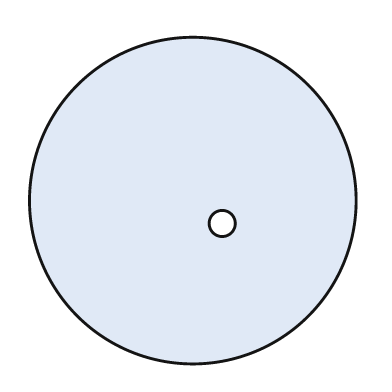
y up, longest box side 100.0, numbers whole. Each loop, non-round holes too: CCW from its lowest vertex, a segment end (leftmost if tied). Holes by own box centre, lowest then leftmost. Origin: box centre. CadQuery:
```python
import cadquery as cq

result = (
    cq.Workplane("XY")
    .moveTo(0.0, 0.0)
    .circle(50.0)
    .moveTo(9.0, -7.0)
    .circle(4.0)
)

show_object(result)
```